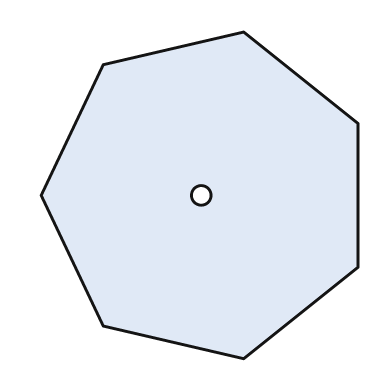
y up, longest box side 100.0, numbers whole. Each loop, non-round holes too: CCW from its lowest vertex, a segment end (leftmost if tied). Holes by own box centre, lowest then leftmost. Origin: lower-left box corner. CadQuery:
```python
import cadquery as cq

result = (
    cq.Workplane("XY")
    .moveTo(62.0, 0.0)
    .lineTo(97.0, 28.0)
    .lineTo(97.0, 72.0)
    .lineTo(62.0, 100.0)
    .lineTo(19.0, 90.0)
    .lineTo(0.0, 50.0)
    .lineTo(19.0, 10.0)
    .close()
    .moveTo(49.0, 50.0)
    .circle(3.0)
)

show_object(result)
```